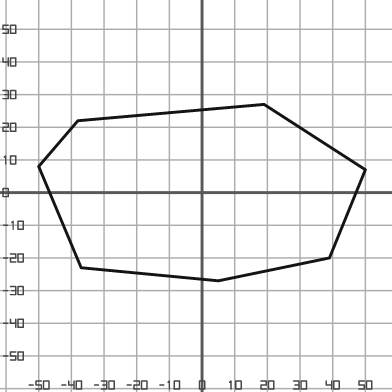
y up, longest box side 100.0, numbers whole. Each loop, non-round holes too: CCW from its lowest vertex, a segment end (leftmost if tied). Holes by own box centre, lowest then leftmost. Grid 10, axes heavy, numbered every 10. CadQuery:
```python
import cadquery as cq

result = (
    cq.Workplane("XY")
    .moveTo(5.0, -27.0)
    .lineTo(39.0, -20.0)
    .lineTo(50.0, 7.0)
    .lineTo(19.0, 27.0)
    .lineTo(-38.0, 22.0)
    .lineTo(-50.0, 8.0)
    .lineTo(-37.0, -23.0)
    .close()
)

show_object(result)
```